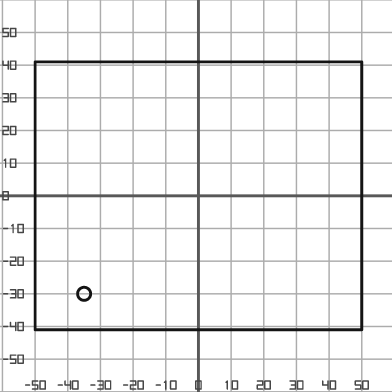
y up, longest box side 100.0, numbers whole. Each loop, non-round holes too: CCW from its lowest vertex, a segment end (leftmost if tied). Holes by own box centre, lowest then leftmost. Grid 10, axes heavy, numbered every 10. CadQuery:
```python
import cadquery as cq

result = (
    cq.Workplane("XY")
    .moveTo(-50.0, -41.0)
    .lineTo(50.0, -41.0)
    .lineTo(50.0, 41.0)
    .lineTo(-50.0, 41.0)
    .close()
    .moveTo(-35.0, -30.0)
    .circle(2.0)
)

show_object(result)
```